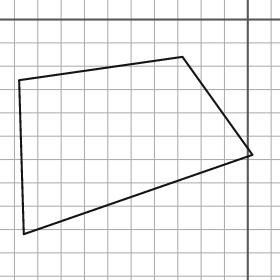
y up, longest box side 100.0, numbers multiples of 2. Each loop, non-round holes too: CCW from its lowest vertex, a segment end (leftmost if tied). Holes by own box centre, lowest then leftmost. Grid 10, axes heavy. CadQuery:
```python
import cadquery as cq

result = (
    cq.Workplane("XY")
    .moveTo(-96.0, -92.0)
    .lineTo(2.0, -58.0)
    .lineTo(-28.0, -16.0)
    .lineTo(-98.0, -26.0)
    .close()
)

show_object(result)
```